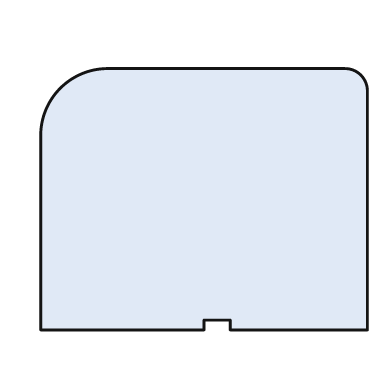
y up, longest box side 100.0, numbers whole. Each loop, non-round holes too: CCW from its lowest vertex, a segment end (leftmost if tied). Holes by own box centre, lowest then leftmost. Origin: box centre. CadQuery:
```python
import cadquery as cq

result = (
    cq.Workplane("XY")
    .moveTo(-50.0, -40.0)
    .lineTo(0.0, -40.0)
    .lineTo(0.0, -37.0)
    .lineTo(8.0, -37.0)
    .lineTo(8.0, -40.0)
    .lineTo(50.0, -40.0)
    .lineTo(50.0, 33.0)
    .threePointArc((48.0, 38.0), (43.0, 40.0))
    .lineTo(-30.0, 40.0)
    .threePointArc((-44.0, 34.0), (-50.0, 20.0))
    .close()
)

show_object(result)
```